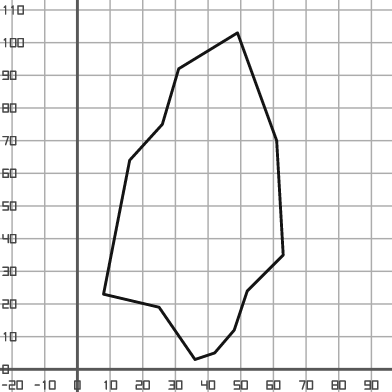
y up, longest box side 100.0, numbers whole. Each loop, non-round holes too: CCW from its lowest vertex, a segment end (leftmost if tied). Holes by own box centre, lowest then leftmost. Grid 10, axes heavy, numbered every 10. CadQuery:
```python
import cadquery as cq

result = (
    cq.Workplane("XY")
    .moveTo(36.0, 3.0)
    .lineTo(42.0, 5.0)
    .lineTo(48.0, 12.0)
    .lineTo(52.0, 24.0)
    .lineTo(63.0, 35.0)
    .lineTo(61.0, 70.0)
    .lineTo(49.0, 103.0)
    .lineTo(31.0, 92.0)
    .lineTo(26.0, 75.0)
    .lineTo(16.0, 64.0)
    .lineTo(8.0, 23.0)
    .lineTo(25.0, 19.0)
    .close()
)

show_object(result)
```